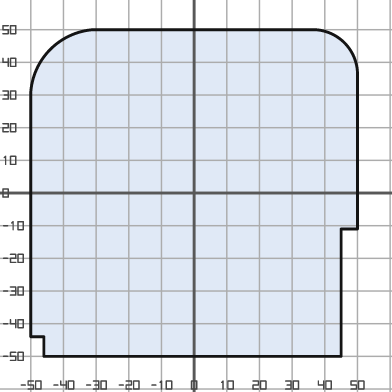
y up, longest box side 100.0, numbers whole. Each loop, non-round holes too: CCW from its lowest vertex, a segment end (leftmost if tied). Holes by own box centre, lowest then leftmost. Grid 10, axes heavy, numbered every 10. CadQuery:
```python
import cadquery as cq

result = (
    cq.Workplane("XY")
    .moveTo(-46.0, -50.0)
    .lineTo(45.0, -50.0)
    .lineTo(45.0, -11.0)
    .lineTo(50.0, -11.0)
    .lineTo(50.0, 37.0)
    .threePointArc((46.0, 46.0), (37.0, 50.0))
    .lineTo(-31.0, 50.0)
    .threePointArc((-44.0, 44.0), (-50.0, 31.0))
    .lineTo(-50.0, -44.0)
    .lineTo(-46.0, -44.0)
    .close()
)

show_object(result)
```